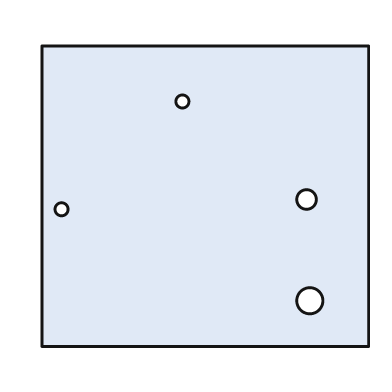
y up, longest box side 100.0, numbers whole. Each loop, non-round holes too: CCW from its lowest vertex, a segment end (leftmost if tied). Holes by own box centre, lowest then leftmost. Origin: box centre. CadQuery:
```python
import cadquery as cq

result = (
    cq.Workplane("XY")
    .moveTo(-50.0, -46.0)
    .lineTo(50.0, -46.0)
    .lineTo(50.0, 46.0)
    .lineTo(-50.0, 46.0)
    .close()
    .moveTo(32.0, -32.0)
    .circle(4.0)
    .moveTo(-44.0, -4.0)
    .circle(2.0)
    .moveTo(31.0, -1.0)
    .circle(3.0)
    .moveTo(-7.0, 29.0)
    .circle(2.0)
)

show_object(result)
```